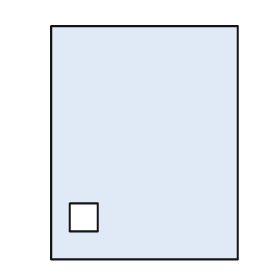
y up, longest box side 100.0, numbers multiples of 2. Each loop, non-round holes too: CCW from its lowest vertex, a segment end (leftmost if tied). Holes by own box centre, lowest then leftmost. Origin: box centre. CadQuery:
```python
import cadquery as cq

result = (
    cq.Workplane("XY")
    .moveTo(-40.0, -50.0)
    .lineTo(40.0, -50.0)
    .lineTo(40.0, 50.0)
    .lineTo(-40.0, 50.0)
    .close()
    .moveTo(-32.0, -38.0)
    .lineTo(-20.0, -38.0)
    .lineTo(-20.0, -26.0)
    .lineTo(-32.0, -26.0)
    .close()
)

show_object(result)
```